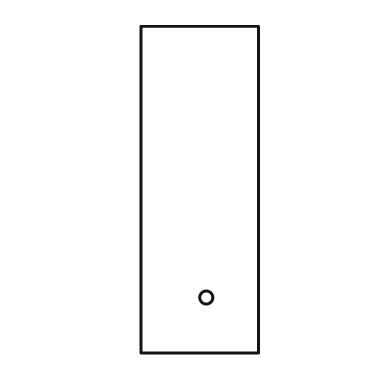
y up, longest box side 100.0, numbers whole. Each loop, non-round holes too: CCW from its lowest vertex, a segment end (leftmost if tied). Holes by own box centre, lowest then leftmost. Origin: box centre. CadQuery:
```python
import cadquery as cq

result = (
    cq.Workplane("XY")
    .moveTo(-18.0, -50.0)
    .lineTo(18.0, -50.0)
    .lineTo(18.0, 50.0)
    .lineTo(-18.0, 50.0)
    .close()
    .moveTo(2.0, -33.0)
    .circle(2.0)
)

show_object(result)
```